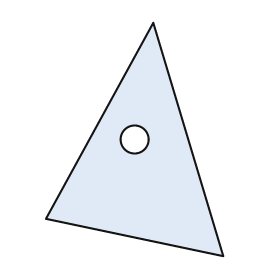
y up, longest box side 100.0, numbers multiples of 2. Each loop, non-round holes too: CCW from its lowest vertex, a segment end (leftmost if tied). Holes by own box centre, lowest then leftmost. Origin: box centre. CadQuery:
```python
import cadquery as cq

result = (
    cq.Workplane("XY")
    .moveTo(38.0, -50.0)
    .lineTo(8.0, 50.0)
    .lineTo(-38.0, -34.0)
    .close()
    .moveTo(0.0, 0.0)
    .circle(6.0)
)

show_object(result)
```